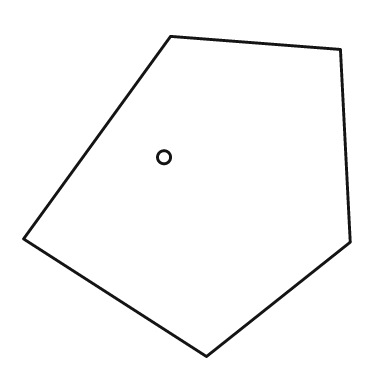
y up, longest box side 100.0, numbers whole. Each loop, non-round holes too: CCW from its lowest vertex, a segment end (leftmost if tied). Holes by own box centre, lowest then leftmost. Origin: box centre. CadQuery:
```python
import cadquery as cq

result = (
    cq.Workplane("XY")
    .moveTo(6.0, -49.0)
    .lineTo(50.0, -14.0)
    .lineTo(47.0, 45.0)
    .lineTo(-5.0, 49.0)
    .lineTo(-50.0, -13.0)
    .close()
    .moveTo(-7.0, 12.0)
    .circle(2.0)
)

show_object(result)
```